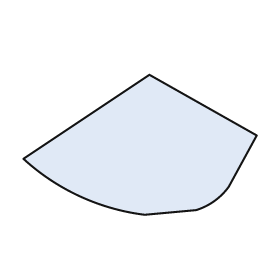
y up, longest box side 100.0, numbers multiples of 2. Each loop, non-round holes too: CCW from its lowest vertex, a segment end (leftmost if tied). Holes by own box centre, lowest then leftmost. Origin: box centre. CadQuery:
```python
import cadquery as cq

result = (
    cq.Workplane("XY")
    .moveTo(2.0, -30.0)
    .lineTo(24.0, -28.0)
    .threePointArc((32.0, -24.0), (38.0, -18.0))
    .lineTo(50.0, 4.0)
    .lineTo(4.0, 30.0)
    .lineTo(-50.0, -6.0)
    .threePointArc((-26.0, -22.0), (2.0, -30.0))
    .close()
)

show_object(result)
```